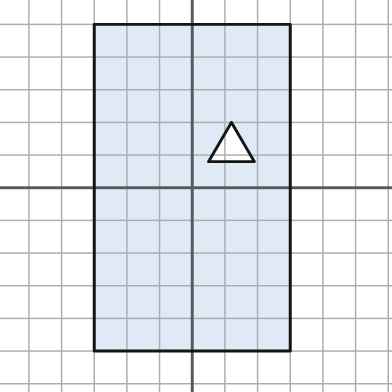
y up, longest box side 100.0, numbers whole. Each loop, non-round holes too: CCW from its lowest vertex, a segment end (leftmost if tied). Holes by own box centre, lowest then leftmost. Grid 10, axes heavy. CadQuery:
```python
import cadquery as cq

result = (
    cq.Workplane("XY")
    .moveTo(-30.0, -50.0)
    .lineTo(30.0, -50.0)
    .lineTo(30.0, 50.0)
    .lineTo(-30.0, 50.0)
    .close()
    .moveTo(5.0, 8.0)
    .lineTo(19.0, 8.0)
    .lineTo(12.0, 20.0)
    .close()
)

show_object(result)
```